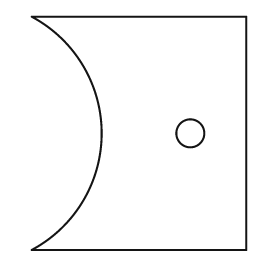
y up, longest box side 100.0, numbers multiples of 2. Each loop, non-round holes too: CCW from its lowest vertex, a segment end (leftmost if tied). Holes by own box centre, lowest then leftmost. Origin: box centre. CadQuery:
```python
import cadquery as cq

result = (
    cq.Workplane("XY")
    .moveTo(-46.0, -50.0)
    .lineTo(46.0, -50.0)
    .lineTo(46.0, 50.0)
    .lineTo(-46.0, 50.0)
    .threePointArc((-16.0, 0.0), (-46.0, -50.0))
    .close()
    .moveTo(22.0, 0.0)
    .circle(6.0)
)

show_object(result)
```